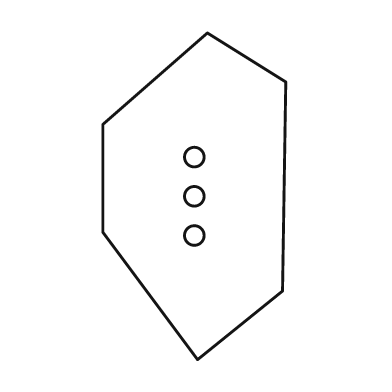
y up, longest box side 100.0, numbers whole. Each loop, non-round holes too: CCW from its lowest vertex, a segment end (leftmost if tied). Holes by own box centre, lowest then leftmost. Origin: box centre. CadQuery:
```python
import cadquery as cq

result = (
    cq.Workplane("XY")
    .moveTo(1.0, -50.0)
    .lineTo(27.0, -29.0)
    .lineTo(28.0, 35.0)
    .lineTo(4.0, 50.0)
    .lineTo(-28.0, 22.0)
    .lineTo(-28.0, -11.0)
    .close()
    .moveTo(0.0, -12.0)
    .circle(3.0)
    .moveTo(0.0, 0.0)
    .circle(3.0)
    .moveTo(0.0, 12.0)
    .circle(3.0)
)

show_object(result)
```